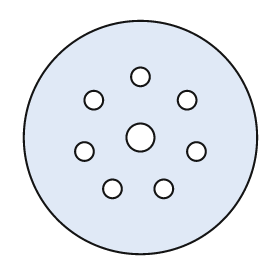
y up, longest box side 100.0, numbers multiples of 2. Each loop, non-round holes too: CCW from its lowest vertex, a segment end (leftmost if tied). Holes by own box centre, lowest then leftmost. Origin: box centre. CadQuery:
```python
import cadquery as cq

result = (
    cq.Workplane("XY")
    .moveTo(0.0, 0.0)
    .circle(50.0)
    .moveTo(-12.0, -22.0)
    .circle(4.0)
    .moveTo(10.0, -22.0)
    .circle(4.0)
    .moveTo(-24.0, -6.0)
    .circle(4.0)
    .moveTo(24.0, -6.0)
    .circle(4.0)
    .moveTo(0.0, 0.0)
    .circle(6.0)
    .moveTo(-20.0, 16.0)
    .circle(4.0)
    .moveTo(20.0, 16.0)
    .circle(4.0)
    .moveTo(0.0, 26.0)
    .circle(4.0)
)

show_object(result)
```